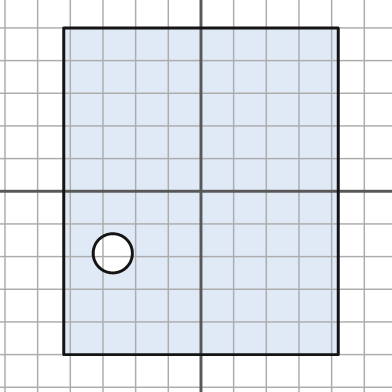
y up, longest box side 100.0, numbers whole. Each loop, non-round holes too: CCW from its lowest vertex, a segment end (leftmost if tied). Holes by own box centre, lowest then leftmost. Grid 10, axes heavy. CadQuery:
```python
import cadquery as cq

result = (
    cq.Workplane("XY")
    .moveTo(-42.0, -50.0)
    .lineTo(42.0, -50.0)
    .lineTo(42.0, 50.0)
    .lineTo(-42.0, 50.0)
    .close()
    .moveTo(-27.0, -19.0)
    .circle(6.0)
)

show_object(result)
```